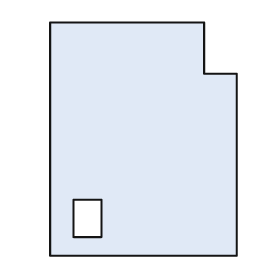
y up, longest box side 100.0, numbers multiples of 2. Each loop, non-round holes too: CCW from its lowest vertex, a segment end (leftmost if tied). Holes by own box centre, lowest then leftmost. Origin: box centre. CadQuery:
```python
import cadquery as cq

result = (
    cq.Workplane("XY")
    .moveTo(-40.0, -50.0)
    .lineTo(40.0, -50.0)
    .lineTo(40.0, 28.0)
    .lineTo(26.0, 28.0)
    .lineTo(26.0, 50.0)
    .lineTo(-40.0, 50.0)
    .close()
    .moveTo(-30.0, -42.0)
    .lineTo(-18.0, -42.0)
    .lineTo(-18.0, -26.0)
    .lineTo(-30.0, -26.0)
    .close()
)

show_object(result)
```